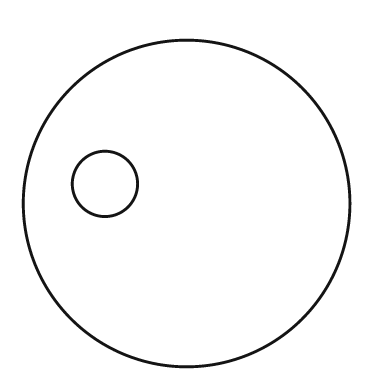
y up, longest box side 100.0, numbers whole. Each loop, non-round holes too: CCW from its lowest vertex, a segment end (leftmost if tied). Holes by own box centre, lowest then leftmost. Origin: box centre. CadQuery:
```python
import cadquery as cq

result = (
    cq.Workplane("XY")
    .moveTo(0.0, 0.0)
    .circle(50.0)
    .moveTo(-25.0, 6.0)
    .circle(10.0)
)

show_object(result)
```